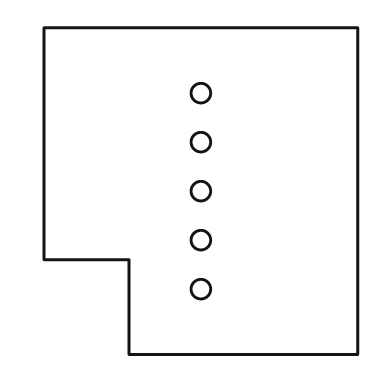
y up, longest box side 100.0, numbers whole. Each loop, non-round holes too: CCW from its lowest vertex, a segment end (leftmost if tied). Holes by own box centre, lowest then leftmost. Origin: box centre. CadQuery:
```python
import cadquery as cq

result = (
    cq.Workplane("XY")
    .moveTo(-22.0, -50.0)
    .lineTo(48.0, -50.0)
    .lineTo(48.0, 50.0)
    .lineTo(-48.0, 50.0)
    .lineTo(-48.0, -21.0)
    .lineTo(-22.0, -21.0)
    .close()
    .moveTo(0.0, -30.0)
    .circle(3.0)
    .moveTo(0.0, -15.0)
    .circle(3.0)
    .moveTo(0.0, 0.0)
    .circle(3.0)
    .moveTo(0.0, 15.0)
    .circle(3.0)
    .moveTo(0.0, 30.0)
    .circle(3.0)
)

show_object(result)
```